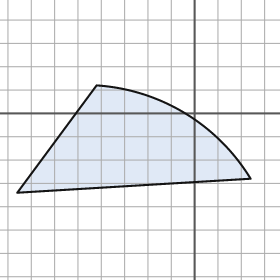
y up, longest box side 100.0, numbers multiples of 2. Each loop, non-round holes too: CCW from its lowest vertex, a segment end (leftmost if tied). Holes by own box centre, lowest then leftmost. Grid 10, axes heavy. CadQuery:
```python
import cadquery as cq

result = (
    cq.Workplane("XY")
    .moveTo(-76.0, -34.0)
    .lineTo(24.0, -28.0)
    .threePointArc((-4.0, 0.0), (-42.0, 12.0))
    .close()
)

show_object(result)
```